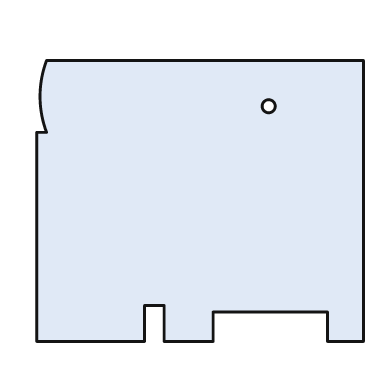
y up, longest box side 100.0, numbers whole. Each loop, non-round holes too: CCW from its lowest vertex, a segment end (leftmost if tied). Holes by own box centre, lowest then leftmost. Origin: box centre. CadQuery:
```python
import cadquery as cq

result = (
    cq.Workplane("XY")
    .moveTo(-50.0, -43.0)
    .lineTo(-17.0, -43.0)
    .lineTo(-17.0, -32.0)
    .lineTo(-11.0, -32.0)
    .lineTo(-11.0, -43.0)
    .lineTo(4.0, -43.0)
    .lineTo(4.0, -34.0)
    .lineTo(39.0, -34.0)
    .lineTo(39.0, -43.0)
    .lineTo(50.0, -43.0)
    .lineTo(50.0, 43.0)
    .lineTo(-47.0, 43.0)
    .threePointArc((-49.0, 32.0), (-47.0, 21.0))
    .lineTo(-50.0, 21.0)
    .close()
    .moveTo(21.0, 29.0)
    .circle(2.0)
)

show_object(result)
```